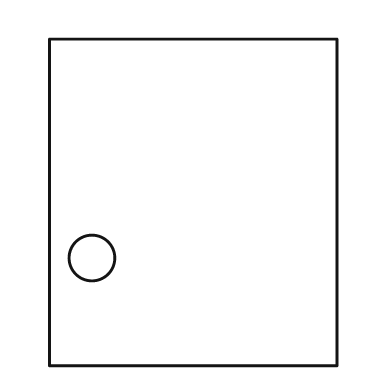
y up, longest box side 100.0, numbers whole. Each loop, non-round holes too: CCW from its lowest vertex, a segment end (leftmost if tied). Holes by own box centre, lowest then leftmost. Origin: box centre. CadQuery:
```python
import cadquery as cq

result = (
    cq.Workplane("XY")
    .moveTo(-44.0, -50.0)
    .lineTo(44.0, -50.0)
    .lineTo(44.0, 50.0)
    .lineTo(-44.0, 50.0)
    .close()
    .moveTo(-31.0, -17.0)
    .circle(7.0)
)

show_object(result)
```